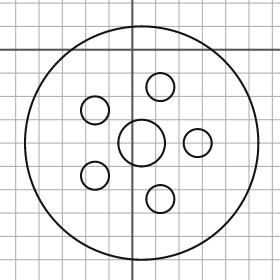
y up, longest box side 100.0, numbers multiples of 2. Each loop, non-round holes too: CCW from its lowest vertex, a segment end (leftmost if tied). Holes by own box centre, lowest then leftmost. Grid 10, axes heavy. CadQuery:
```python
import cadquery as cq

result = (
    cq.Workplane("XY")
    .moveTo(4.0, -40.0)
    .circle(50.0)
    .moveTo(12.0, -64.0)
    .circle(6.0)
    .moveTo(-16.0, -54.0)
    .circle(6.0)
    .moveTo(4.0, -40.0)
    .circle(10.0)
    .moveTo(28.0, -40.0)
    .circle(6.0)
    .moveTo(-16.0, -26.0)
    .circle(6.0)
    .moveTo(12.0, -16.0)
    .circle(6.0)
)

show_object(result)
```